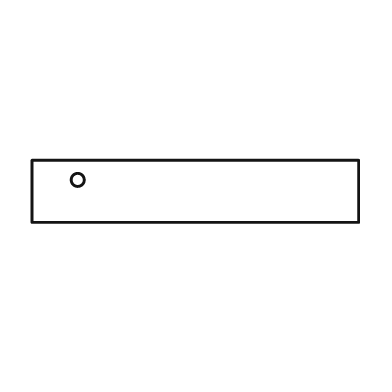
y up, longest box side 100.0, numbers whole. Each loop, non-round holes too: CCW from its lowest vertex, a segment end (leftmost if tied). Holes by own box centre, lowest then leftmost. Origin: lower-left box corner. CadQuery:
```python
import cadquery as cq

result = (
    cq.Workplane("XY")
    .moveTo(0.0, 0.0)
    .lineTo(100.0, 0.0)
    .lineTo(100.0, 19.0)
    .lineTo(0.0, 19.0)
    .close()
    .moveTo(14.0, 13.0)
    .circle(2.0)
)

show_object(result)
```